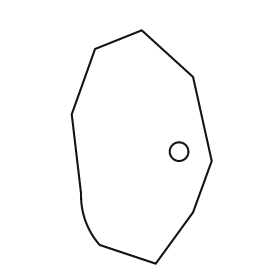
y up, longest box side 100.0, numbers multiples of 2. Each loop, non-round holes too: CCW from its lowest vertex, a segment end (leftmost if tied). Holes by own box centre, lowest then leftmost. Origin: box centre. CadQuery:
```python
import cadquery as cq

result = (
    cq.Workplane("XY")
    .moveTo(6.0, -50.0)
    .lineTo(22.0, -28.0)
    .lineTo(30.0, -6.0)
    .lineTo(22.0, 30.0)
    .lineTo(0.0, 50.0)
    .lineTo(-20.0, 42.0)
    .lineTo(-30.0, 14.0)
    .lineTo(-26.0, -20.0)
    .threePointArc((-24.0, -32.0), (-18.0, -42.0))
    .close()
    .moveTo(16.0, -2.0)
    .circle(4.0)
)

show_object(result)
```